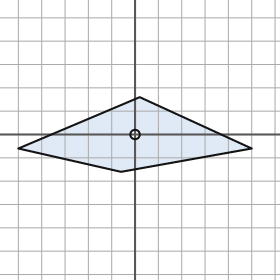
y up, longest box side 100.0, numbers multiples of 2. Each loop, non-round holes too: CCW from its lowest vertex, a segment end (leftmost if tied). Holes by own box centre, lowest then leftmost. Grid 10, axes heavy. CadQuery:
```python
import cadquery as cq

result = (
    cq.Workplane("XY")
    .moveTo(-6.0, -16.0)
    .lineTo(50.0, -6.0)
    .lineTo(2.0, 16.0)
    .lineTo(-50.0, -6.0)
    .close()
    .moveTo(0.0, 0.0)
    .circle(2.0)
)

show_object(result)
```